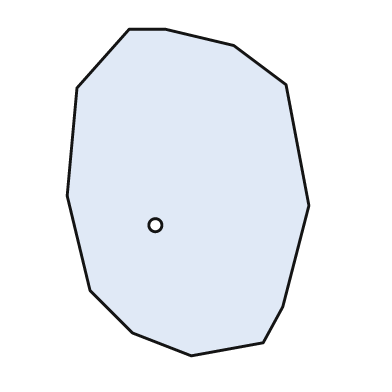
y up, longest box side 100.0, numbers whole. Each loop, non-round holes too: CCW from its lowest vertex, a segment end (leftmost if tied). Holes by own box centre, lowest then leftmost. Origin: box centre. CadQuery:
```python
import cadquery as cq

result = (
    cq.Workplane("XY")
    .moveTo(1.0, -50.0)
    .lineTo(23.0, -46.0)
    .lineTo(29.0, -35.0)
    .lineTo(37.0, -4.0)
    .lineTo(30.0, 33.0)
    .lineTo(14.0, 45.0)
    .lineTo(-7.0, 50.0)
    .lineTo(-18.0, 50.0)
    .lineTo(-34.0, 32.0)
    .lineTo(-37.0, -1.0)
    .lineTo(-30.0, -30.0)
    .lineTo(-17.0, -43.0)
    .close()
    .moveTo(-10.0, -10.0)
    .circle(2.0)
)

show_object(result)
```